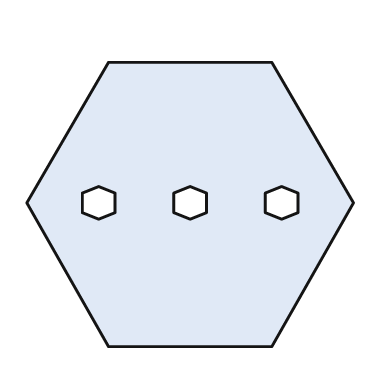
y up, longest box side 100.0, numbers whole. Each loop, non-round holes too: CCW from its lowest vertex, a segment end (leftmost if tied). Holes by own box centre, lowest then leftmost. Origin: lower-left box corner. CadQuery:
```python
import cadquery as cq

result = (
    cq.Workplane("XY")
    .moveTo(25.0, 0.0)
    .lineTo(75.0, 0.0)
    .lineTo(100.0, 44.0)
    .lineTo(75.0, 87.0)
    .lineTo(25.0, 87.0)
    .lineTo(0.0, 44.0)
    .close()
    .moveTo(22.0, 39.0)
    .lineTo(27.0, 41.0)
    .lineTo(27.0, 47.0)
    .lineTo(22.0, 49.0)
    .lineTo(17.0, 47.0)
    .lineTo(17.0, 41.0)
    .close()
    .moveTo(50.0, 39.0)
    .lineTo(55.0, 41.0)
    .lineTo(55.0, 47.0)
    .lineTo(50.0, 49.0)
    .lineTo(45.0, 47.0)
    .lineTo(45.0, 41.0)
    .close()
    .moveTo(78.0, 39.0)
    .lineTo(83.0, 41.0)
    .lineTo(83.0, 47.0)
    .lineTo(78.0, 49.0)
    .lineTo(73.0, 47.0)
    .lineTo(73.0, 41.0)
    .close()
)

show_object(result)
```